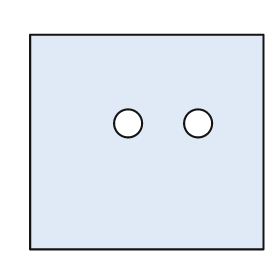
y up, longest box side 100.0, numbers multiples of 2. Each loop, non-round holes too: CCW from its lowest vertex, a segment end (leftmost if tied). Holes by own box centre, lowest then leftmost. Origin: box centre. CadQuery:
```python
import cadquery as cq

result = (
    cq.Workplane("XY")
    .moveTo(-50.0, -46.0)
    .lineTo(50.0, -46.0)
    .lineTo(50.0, 46.0)
    .lineTo(-50.0, 46.0)
    .close()
    .moveTo(-8.0, 8.0)
    .circle(6.0)
    .moveTo(22.0, 8.0)
    .circle(6.0)
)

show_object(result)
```